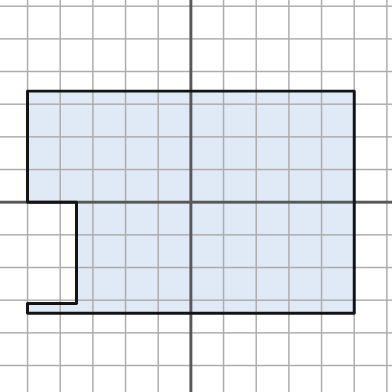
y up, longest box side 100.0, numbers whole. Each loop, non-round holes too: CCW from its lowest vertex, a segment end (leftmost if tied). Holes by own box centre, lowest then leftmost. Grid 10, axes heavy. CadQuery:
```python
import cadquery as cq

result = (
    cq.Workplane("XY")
    .moveTo(-50.0, -34.0)
    .lineTo(50.0, -34.0)
    .lineTo(50.0, 34.0)
    .lineTo(-50.0, 34.0)
    .lineTo(-50.0, 0.0)
    .lineTo(-35.0, 0.0)
    .lineTo(-35.0, -31.0)
    .lineTo(-50.0, -31.0)
    .close()
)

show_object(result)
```